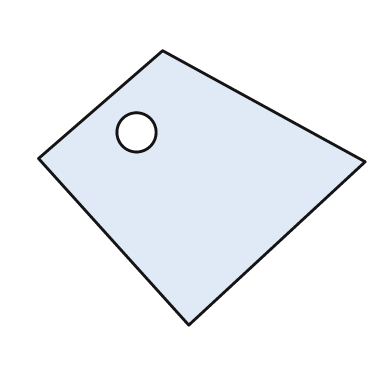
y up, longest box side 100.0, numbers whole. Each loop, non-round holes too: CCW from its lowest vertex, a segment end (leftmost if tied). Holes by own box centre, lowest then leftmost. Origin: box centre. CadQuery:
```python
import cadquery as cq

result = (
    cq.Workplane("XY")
    .moveTo(-4.0, -42.0)
    .lineTo(50.0, 8.0)
    .lineTo(-12.0, 42.0)
    .lineTo(-50.0, 9.0)
    .close()
    .moveTo(-20.0, 17.0)
    .circle(6.0)
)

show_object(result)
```